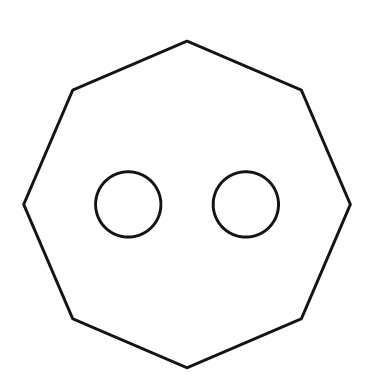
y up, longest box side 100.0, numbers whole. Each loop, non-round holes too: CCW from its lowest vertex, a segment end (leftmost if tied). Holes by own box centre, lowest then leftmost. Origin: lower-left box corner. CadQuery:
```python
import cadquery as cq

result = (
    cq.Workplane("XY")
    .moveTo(50.0, 0.0)
    .lineTo(85.0, 15.0)
    .lineTo(100.0, 50.0)
    .lineTo(85.0, 85.0)
    .lineTo(50.0, 100.0)
    .lineTo(15.0, 85.0)
    .lineTo(0.0, 50.0)
    .lineTo(15.0, 15.0)
    .close()
    .moveTo(32.0, 50.0)
    .circle(10.0)
    .moveTo(68.0, 50.0)
    .circle(10.0)
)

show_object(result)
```